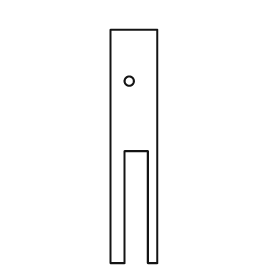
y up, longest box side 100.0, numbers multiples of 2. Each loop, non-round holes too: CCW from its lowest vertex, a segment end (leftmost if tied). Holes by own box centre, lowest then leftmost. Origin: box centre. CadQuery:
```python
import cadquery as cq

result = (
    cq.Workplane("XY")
    .moveTo(-10.0, -50.0)
    .lineTo(-4.0, -50.0)
    .lineTo(-4.0, -2.0)
    .lineTo(6.0, -2.0)
    .lineTo(6.0, -50.0)
    .lineTo(10.0, -50.0)
    .lineTo(10.0, 50.0)
    .lineTo(-10.0, 50.0)
    .close()
    .moveTo(-2.0, 28.0)
    .circle(2.0)
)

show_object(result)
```